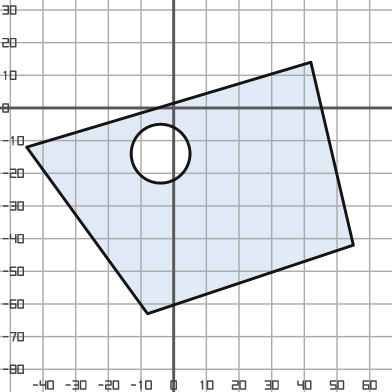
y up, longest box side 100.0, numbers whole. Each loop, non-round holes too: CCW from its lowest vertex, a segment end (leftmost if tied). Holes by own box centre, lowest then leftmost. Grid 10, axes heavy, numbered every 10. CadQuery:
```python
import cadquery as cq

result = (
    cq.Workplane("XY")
    .moveTo(-8.0, -63.0)
    .lineTo(55.0, -42.0)
    .lineTo(42.0, 14.0)
    .lineTo(-45.0, -12.0)
    .close()
    .moveTo(-4.0, -14.0)
    .circle(9.0)
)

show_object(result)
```